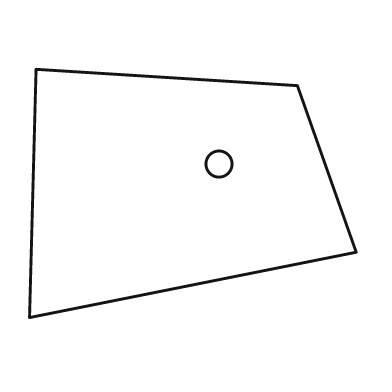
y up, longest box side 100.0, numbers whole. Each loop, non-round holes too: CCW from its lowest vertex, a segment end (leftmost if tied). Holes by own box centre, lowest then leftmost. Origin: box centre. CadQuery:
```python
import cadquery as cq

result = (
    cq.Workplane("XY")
    .moveTo(-50.0, -38.0)
    .lineTo(50.0, -18.0)
    .lineTo(32.0, 33.0)
    .lineTo(-48.0, 38.0)
    .close()
    .moveTo(8.0, 9.0)
    .circle(4.0)
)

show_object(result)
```